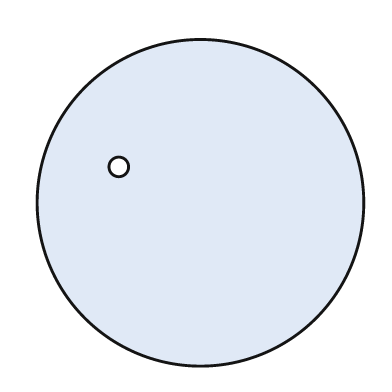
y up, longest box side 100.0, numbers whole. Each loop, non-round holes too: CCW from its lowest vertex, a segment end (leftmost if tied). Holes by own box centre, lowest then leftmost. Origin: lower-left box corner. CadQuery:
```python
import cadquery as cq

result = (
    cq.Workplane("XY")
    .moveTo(50.0, 50.0)
    .circle(50.0)
    .moveTo(25.0, 61.0)
    .circle(3.0)
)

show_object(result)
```